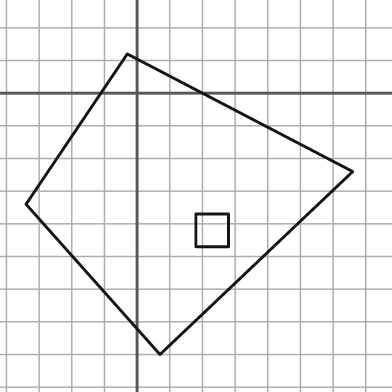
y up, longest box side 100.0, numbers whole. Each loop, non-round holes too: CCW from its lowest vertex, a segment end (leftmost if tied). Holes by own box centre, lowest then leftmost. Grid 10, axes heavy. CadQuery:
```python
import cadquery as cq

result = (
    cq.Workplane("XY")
    .moveTo(7.0, -80.0)
    .lineTo(66.0, -24.0)
    .lineTo(-3.0, 12.0)
    .lineTo(-34.0, -34.0)
    .close()
    .moveTo(18.0, -47.0)
    .lineTo(28.0, -47.0)
    .lineTo(28.0, -37.0)
    .lineTo(18.0, -37.0)
    .close()
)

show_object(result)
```